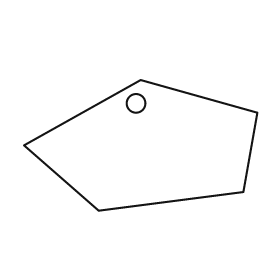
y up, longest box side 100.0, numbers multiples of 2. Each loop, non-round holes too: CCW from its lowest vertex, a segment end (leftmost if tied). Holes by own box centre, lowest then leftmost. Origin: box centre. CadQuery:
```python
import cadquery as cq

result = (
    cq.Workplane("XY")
    .moveTo(-18.0, -28.0)
    .lineTo(44.0, -20.0)
    .lineTo(50.0, 14.0)
    .lineTo(0.0, 28.0)
    .lineTo(-50.0, 0.0)
    .close()
    .moveTo(-2.0, 18.0)
    .circle(4.0)
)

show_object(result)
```